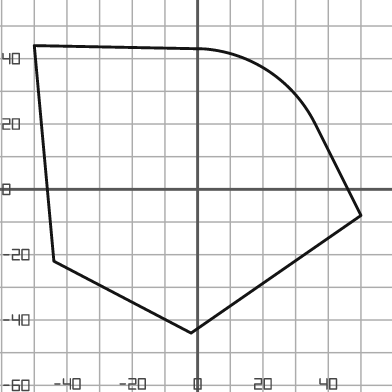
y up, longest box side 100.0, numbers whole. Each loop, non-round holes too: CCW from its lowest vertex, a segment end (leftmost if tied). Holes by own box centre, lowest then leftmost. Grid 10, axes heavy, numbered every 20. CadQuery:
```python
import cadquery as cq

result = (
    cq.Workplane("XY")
    .moveTo(-2.0, -44.0)
    .lineTo(50.0, -8.0)
    .lineTo(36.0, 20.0)
    .threePointArc((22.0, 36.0), (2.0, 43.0))
    .lineTo(-50.0, 44.0)
    .lineTo(-44.0, -22.0)
    .close()
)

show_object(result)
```